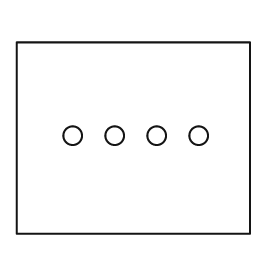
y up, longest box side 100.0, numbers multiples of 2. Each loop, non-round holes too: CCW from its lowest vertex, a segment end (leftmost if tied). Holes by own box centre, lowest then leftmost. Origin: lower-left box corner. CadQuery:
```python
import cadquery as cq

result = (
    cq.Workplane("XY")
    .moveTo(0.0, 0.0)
    .lineTo(100.0, 0.0)
    .lineTo(100.0, 82.0)
    .lineTo(0.0, 82.0)
    .close()
    .moveTo(24.0, 42.0)
    .circle(4.0)
    .moveTo(42.0, 42.0)
    .circle(4.0)
    .moveTo(60.0, 42.0)
    .circle(4.0)
    .moveTo(78.0, 42.0)
    .circle(4.0)
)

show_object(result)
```